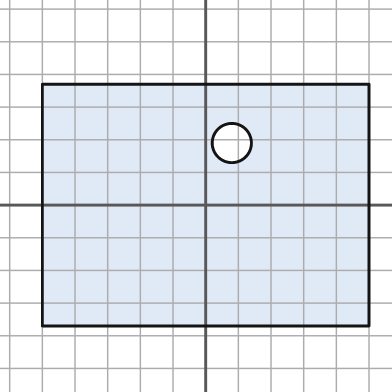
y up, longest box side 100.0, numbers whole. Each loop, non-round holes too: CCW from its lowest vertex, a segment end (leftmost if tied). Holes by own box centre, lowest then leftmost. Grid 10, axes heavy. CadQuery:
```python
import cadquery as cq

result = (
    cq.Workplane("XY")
    .moveTo(-50.0, -37.0)
    .lineTo(50.0, -37.0)
    .lineTo(50.0, 37.0)
    .lineTo(-50.0, 37.0)
    .close()
    .moveTo(8.0, 19.0)
    .circle(6.0)
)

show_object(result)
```